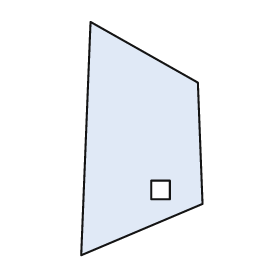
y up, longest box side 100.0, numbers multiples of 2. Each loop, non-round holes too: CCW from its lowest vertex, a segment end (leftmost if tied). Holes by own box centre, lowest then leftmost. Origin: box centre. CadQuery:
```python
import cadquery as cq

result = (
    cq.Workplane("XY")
    .moveTo(-26.0, -50.0)
    .lineTo(26.0, -28.0)
    .lineTo(24.0, 24.0)
    .lineTo(-22.0, 50.0)
    .close()
    .moveTo(4.0, -26.0)
    .lineTo(12.0, -26.0)
    .lineTo(12.0, -18.0)
    .lineTo(4.0, -18.0)
    .close()
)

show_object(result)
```